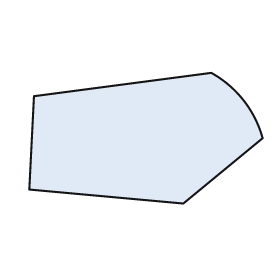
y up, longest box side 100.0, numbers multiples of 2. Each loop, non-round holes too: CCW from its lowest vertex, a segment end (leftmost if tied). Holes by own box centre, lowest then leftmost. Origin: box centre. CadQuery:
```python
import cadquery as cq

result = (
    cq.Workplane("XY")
    .moveTo(16.0, -28.0)
    .lineTo(50.0, 0.0)
    .threePointArc((42.0, 16.0), (28.0, 28.0))
    .lineTo(-48.0, 18.0)
    .lineTo(-50.0, -22.0)
    .close()
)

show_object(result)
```